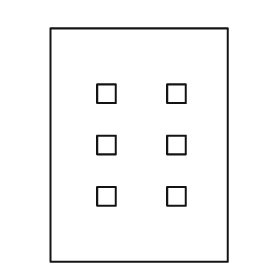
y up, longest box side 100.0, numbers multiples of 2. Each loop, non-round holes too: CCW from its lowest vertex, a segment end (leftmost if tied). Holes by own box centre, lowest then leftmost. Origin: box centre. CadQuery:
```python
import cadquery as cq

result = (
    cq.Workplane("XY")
    .moveTo(-38.0, -50.0)
    .lineTo(38.0, -50.0)
    .lineTo(38.0, 50.0)
    .lineTo(-38.0, 50.0)
    .close()
    .moveTo(-18.0, -26.0)
    .lineTo(-10.0, -26.0)
    .lineTo(-10.0, -18.0)
    .lineTo(-18.0, -18.0)
    .close()
    .moveTo(12.0, -26.0)
    .lineTo(20.0, -26.0)
    .lineTo(20.0, -18.0)
    .lineTo(12.0, -18.0)
    .close()
    .moveTo(-18.0, -4.0)
    .lineTo(-10.0, -4.0)
    .lineTo(-10.0, 4.0)
    .lineTo(-18.0, 4.0)
    .close()
    .moveTo(12.0, -4.0)
    .lineTo(20.0, -4.0)
    .lineTo(20.0, 4.0)
    .lineTo(12.0, 4.0)
    .close()
    .moveTo(-18.0, 18.0)
    .lineTo(-10.0, 18.0)
    .lineTo(-10.0, 26.0)
    .lineTo(-18.0, 26.0)
    .close()
    .moveTo(12.0, 18.0)
    .lineTo(20.0, 18.0)
    .lineTo(20.0, 26.0)
    .lineTo(12.0, 26.0)
    .close()
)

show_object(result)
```